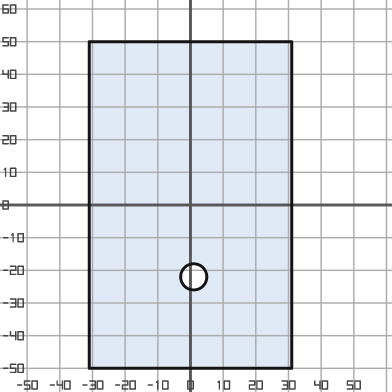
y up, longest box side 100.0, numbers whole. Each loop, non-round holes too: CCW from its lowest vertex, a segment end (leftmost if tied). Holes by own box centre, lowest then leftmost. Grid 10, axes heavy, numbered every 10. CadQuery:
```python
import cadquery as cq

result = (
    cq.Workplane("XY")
    .moveTo(-31.0, -50.0)
    .lineTo(31.0, -50.0)
    .lineTo(31.0, 50.0)
    .lineTo(-31.0, 50.0)
    .close()
    .moveTo(1.0, -22.0)
    .circle(4.0)
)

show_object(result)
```